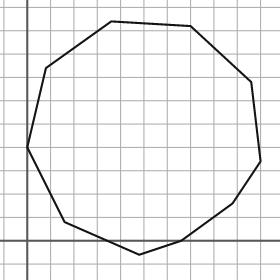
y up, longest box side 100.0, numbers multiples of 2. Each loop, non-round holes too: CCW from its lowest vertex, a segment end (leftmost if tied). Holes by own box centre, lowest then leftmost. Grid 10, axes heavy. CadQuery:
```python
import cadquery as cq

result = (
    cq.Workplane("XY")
    .moveTo(48.0, -6.0)
    .lineTo(66.0, 0.0)
    .lineTo(88.0, 16.0)
    .lineTo(100.0, 34.0)
    .lineTo(96.0, 68.0)
    .lineTo(70.0, 92.0)
    .lineTo(36.0, 94.0)
    .lineTo(8.0, 74.0)
    .lineTo(0.0, 40.0)
    .lineTo(16.0, 8.0)
    .close()
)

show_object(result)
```